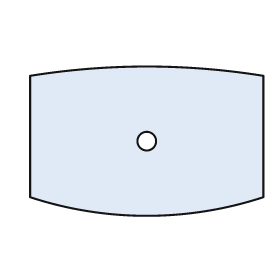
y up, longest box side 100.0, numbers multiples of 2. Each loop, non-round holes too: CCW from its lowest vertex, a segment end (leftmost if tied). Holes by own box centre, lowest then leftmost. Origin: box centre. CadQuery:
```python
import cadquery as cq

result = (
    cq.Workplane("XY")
    .moveTo(-50.0, -24.0)
    .threePointArc((0.0, -32.0), (50.0, -24.0))
    .lineTo(50.0, 28.0)
    .threePointArc((0.0, 32.0), (-50.0, 28.0))
    .close()
    .moveTo(0.0, 0.0)
    .circle(4.0)
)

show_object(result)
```